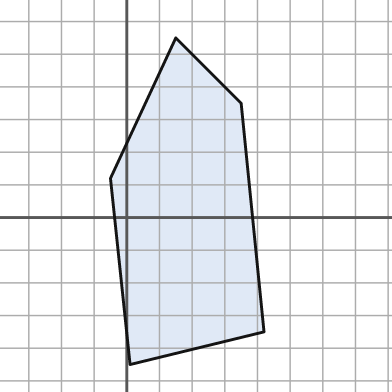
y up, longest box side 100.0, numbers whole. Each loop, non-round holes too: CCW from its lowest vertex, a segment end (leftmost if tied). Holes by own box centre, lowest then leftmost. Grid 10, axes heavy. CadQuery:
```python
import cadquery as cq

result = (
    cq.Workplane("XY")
    .moveTo(1.0, -45.0)
    .lineTo(42.0, -35.0)
    .lineTo(35.0, 35.0)
    .lineTo(15.0, 55.0)
    .lineTo(-5.0, 12.0)
    .close()
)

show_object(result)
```